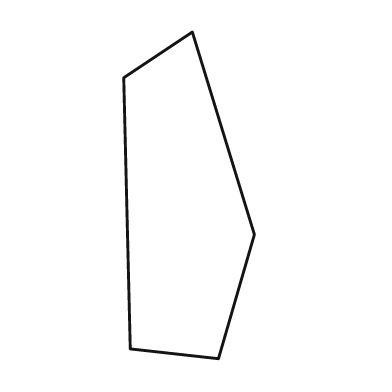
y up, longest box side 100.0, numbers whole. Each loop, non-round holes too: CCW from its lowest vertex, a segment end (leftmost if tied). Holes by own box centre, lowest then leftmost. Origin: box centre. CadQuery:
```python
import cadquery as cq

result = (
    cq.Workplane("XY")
    .moveTo(9.0, -50.0)
    .lineTo(20.0, -12.0)
    .lineTo(1.0, 50.0)
    .lineTo(-20.0, 36.0)
    .lineTo(-18.0, -47.0)
    .close()
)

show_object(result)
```